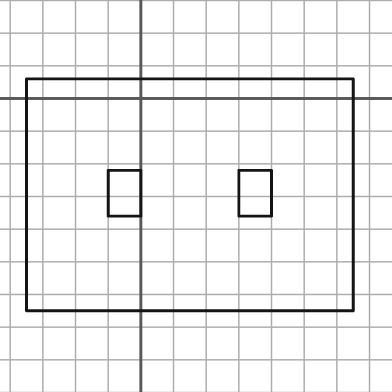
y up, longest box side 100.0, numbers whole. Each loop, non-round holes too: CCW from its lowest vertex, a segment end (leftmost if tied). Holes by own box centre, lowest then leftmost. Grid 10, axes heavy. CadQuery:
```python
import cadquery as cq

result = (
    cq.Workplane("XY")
    .moveTo(-35.0, -65.0)
    .lineTo(65.0, -65.0)
    .lineTo(65.0, 6.0)
    .lineTo(-35.0, 6.0)
    .close()
    .moveTo(-10.0, -36.0)
    .lineTo(0.0, -36.0)
    .lineTo(0.0, -22.0)
    .lineTo(-10.0, -22.0)
    .close()
    .moveTo(30.0, -36.0)
    .lineTo(40.0, -36.0)
    .lineTo(40.0, -22.0)
    .lineTo(30.0, -22.0)
    .close()
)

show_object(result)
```